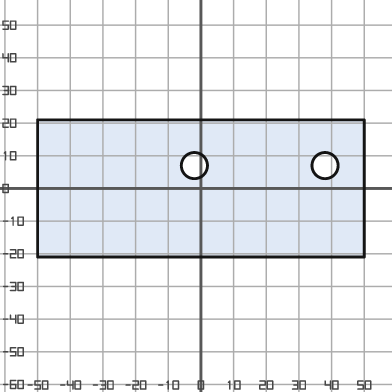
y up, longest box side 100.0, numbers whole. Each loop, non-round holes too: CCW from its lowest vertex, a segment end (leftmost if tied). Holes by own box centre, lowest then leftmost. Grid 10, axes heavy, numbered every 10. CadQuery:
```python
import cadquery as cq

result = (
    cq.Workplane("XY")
    .moveTo(-50.0, -21.0)
    .lineTo(50.0, -21.0)
    .lineTo(50.0, 21.0)
    .lineTo(-50.0, 21.0)
    .close()
    .moveTo(-2.0, 7.0)
    .circle(4.0)
    .moveTo(38.0, 7.0)
    .circle(4.0)
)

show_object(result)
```